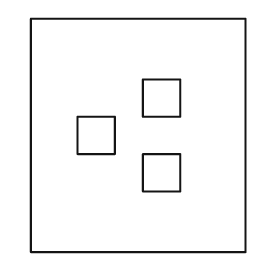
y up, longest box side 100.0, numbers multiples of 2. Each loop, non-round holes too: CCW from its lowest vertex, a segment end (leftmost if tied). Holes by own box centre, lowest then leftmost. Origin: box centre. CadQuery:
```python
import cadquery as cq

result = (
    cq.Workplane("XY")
    .moveTo(-46.0, -50.0)
    .lineTo(46.0, -50.0)
    .lineTo(46.0, 50.0)
    .lineTo(-46.0, 50.0)
    .close()
    .moveTo(2.0, -24.0)
    .lineTo(18.0, -24.0)
    .lineTo(18.0, -8.0)
    .lineTo(2.0, -8.0)
    .close()
    .moveTo(-26.0, -8.0)
    .lineTo(-10.0, -8.0)
    .lineTo(-10.0, 8.0)
    .lineTo(-26.0, 8.0)
    .close()
    .moveTo(2.0, 8.0)
    .lineTo(18.0, 8.0)
    .lineTo(18.0, 24.0)
    .lineTo(2.0, 24.0)
    .close()
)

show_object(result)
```